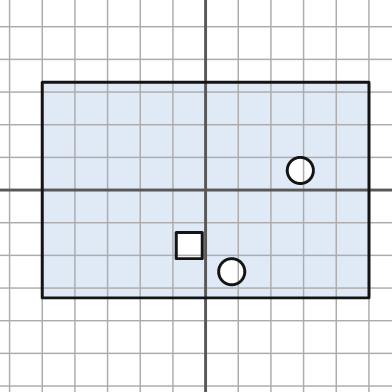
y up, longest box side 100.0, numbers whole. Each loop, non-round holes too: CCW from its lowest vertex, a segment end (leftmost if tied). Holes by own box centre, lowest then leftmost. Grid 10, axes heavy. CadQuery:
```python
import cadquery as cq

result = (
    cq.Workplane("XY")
    .moveTo(-50.0, -33.0)
    .lineTo(50.0, -33.0)
    .lineTo(50.0, 33.0)
    .lineTo(-50.0, 33.0)
    .close()
    .moveTo(8.0, -25.0)
    .circle(4.0)
    .moveTo(-9.0, -21.0)
    .lineTo(-1.0, -21.0)
    .lineTo(-1.0, -13.0)
    .lineTo(-9.0, -13.0)
    .close()
    .moveTo(29.0, 6.0)
    .circle(4.0)
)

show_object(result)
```